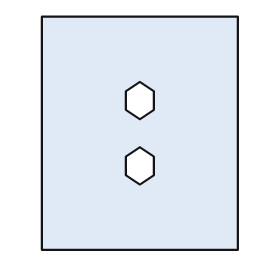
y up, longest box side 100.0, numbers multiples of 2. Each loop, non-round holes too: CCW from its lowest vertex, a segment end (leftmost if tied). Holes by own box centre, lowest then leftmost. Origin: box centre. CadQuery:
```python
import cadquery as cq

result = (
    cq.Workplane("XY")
    .moveTo(-42.0, -50.0)
    .lineTo(42.0, -50.0)
    .lineTo(42.0, 50.0)
    .lineTo(-42.0, 50.0)
    .close()
    .moveTo(0.0, -22.0)
    .lineTo(6.0, -18.0)
    .lineTo(6.0, -10.0)
    .lineTo(0.0, -6.0)
    .lineTo(-6.0, -10.0)
    .lineTo(-6.0, -18.0)
    .close()
    .moveTo(0.0, 6.0)
    .lineTo(6.0, 10.0)
    .lineTo(6.0, 18.0)
    .lineTo(0.0, 22.0)
    .lineTo(-6.0, 18.0)
    .lineTo(-6.0, 10.0)
    .close()
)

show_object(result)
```